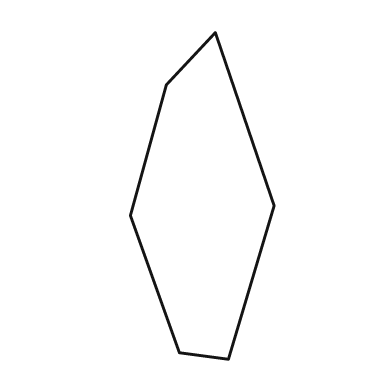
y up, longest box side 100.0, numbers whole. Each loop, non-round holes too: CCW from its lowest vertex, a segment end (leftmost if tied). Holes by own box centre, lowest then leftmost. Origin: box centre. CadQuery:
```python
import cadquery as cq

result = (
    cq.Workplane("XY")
    .moveTo(8.0, -50.0)
    .lineTo(22.0, -3.0)
    .lineTo(4.0, 50.0)
    .lineTo(-11.0, 34.0)
    .lineTo(-22.0, -6.0)
    .lineTo(-7.0, -48.0)
    .close()
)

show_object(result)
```